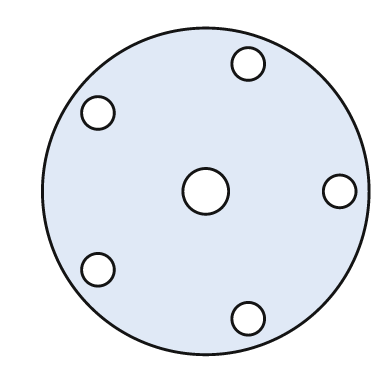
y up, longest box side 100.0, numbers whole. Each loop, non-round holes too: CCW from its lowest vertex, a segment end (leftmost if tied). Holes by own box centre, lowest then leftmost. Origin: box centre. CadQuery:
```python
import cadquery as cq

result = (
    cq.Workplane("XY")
    .moveTo(0.0, 0.0)
    .circle(50.0)
    .moveTo(13.0, -39.0)
    .circle(5.0)
    .moveTo(-33.0, -24.0)
    .circle(5.0)
    .moveTo(0.0, 0.0)
    .circle(7.0)
    .moveTo(41.0, 0.0)
    .circle(5.0)
    .moveTo(-33.0, 24.0)
    .circle(5.0)
    .moveTo(13.0, 39.0)
    .circle(5.0)
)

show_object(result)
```